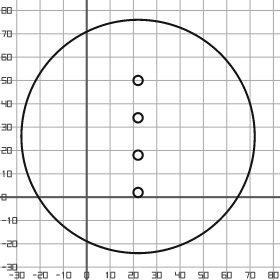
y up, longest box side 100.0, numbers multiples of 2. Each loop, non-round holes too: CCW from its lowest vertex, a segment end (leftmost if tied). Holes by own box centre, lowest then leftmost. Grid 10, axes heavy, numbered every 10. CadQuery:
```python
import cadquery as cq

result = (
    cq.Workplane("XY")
    .moveTo(22.0, 26.0)
    .circle(50.0)
    .moveTo(22.0, 2.0)
    .circle(2.0)
    .moveTo(22.0, 18.0)
    .circle(2.0)
    .moveTo(22.0, 34.0)
    .circle(2.0)
    .moveTo(22.0, 50.0)
    .circle(2.0)
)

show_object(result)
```